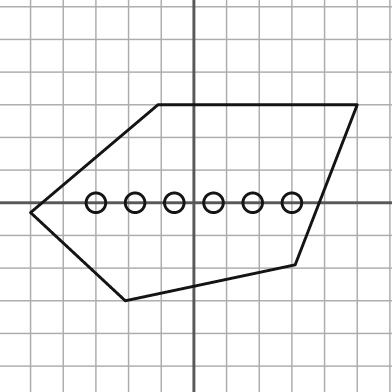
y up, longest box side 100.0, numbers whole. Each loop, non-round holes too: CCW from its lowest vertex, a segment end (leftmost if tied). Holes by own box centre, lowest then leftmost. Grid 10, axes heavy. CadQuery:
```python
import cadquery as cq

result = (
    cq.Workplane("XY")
    .moveTo(-21.0, -30.0)
    .lineTo(31.0, -19.0)
    .lineTo(50.0, 30.0)
    .lineTo(-11.0, 30.0)
    .lineTo(-50.0, -3.0)
    .close()
    .moveTo(-30.0, 0.0)
    .circle(3.0)
    .moveTo(-18.0, 0.0)
    .circle(3.0)
    .moveTo(-6.0, 0.0)
    .circle(3.0)
    .moveTo(6.0, 0.0)
    .circle(3.0)
    .moveTo(18.0, 0.0)
    .circle(3.0)
    .moveTo(30.0, 0.0)
    .circle(3.0)
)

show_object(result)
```